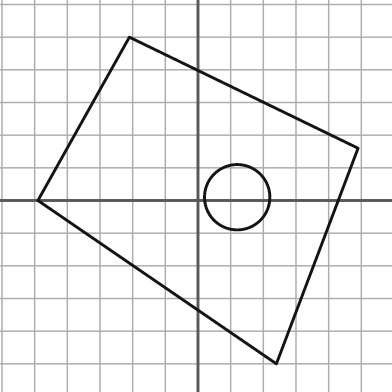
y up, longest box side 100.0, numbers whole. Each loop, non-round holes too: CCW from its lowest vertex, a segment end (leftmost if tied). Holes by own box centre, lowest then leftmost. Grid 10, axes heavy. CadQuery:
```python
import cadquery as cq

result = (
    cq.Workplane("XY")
    .moveTo(24.0, -50.0)
    .lineTo(49.0, 16.0)
    .lineTo(-21.0, 50.0)
    .lineTo(-49.0, 0.0)
    .close()
    .moveTo(12.0, 1.0)
    .circle(10.0)
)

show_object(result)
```